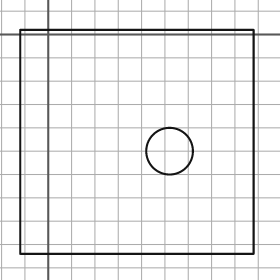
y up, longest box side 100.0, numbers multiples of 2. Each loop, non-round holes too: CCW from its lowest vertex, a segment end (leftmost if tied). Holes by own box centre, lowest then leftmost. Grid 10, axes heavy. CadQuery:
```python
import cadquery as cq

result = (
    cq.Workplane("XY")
    .moveTo(-12.0, -94.0)
    .lineTo(88.0, -94.0)
    .lineTo(88.0, 2.0)
    .lineTo(-12.0, 2.0)
    .close()
    .moveTo(52.0, -50.0)
    .circle(10.0)
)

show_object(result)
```